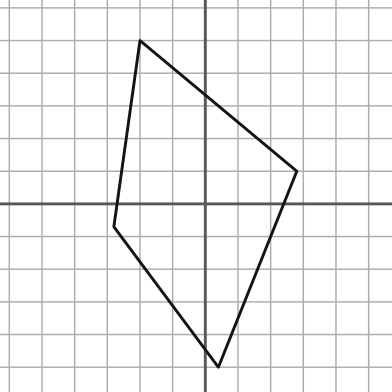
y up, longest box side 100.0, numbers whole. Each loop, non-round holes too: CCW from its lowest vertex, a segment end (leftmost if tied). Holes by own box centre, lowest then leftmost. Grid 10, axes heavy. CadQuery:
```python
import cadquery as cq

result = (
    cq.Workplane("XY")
    .moveTo(4.0, -50.0)
    .lineTo(28.0, 10.0)
    .lineTo(-20.0, 50.0)
    .lineTo(-28.0, -7.0)
    .close()
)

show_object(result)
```